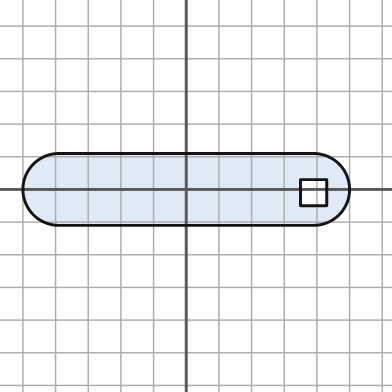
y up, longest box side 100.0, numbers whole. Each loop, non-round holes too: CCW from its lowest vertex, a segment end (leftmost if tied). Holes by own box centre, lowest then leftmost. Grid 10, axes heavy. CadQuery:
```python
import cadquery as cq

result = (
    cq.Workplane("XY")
    .moveTo(-39.0, -11.0)
    .lineTo(39.0, -11.0)
    .threePointArc((50.0, 0.0), (39.0, 11.0))
    .lineTo(-39.0, 11.0)
    .threePointArc((-50.0, 0.0), (-39.0, -11.0))
    .close()
    .moveTo(35.0, -5.0)
    .lineTo(43.0, -5.0)
    .lineTo(43.0, 3.0)
    .lineTo(35.0, 3.0)
    .close()
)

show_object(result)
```